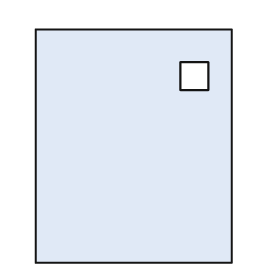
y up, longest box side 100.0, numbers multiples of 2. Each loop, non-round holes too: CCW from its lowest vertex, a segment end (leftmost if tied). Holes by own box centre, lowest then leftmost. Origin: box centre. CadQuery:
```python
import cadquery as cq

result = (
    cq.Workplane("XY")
    .moveTo(-42.0, -50.0)
    .lineTo(42.0, -50.0)
    .lineTo(42.0, 50.0)
    .lineTo(-42.0, 50.0)
    .close()
    .moveTo(20.0, 24.0)
    .lineTo(32.0, 24.0)
    .lineTo(32.0, 36.0)
    .lineTo(20.0, 36.0)
    .close()
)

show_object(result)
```